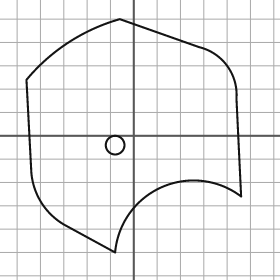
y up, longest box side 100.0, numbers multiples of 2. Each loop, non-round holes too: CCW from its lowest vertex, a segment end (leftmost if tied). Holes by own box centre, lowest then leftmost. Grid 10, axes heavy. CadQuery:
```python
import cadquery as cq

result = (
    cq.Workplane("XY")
    .moveTo(-8.0, -50.0)
    .threePointArc((12.0, -22.0), (46.0, -26.0))
    .lineTo(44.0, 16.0)
    .threePointArc((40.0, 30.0), (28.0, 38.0))
    .lineTo(-6.0, 50.0)
    .threePointArc((-28.0, 40.0), (-46.0, 24.0))
    .lineTo(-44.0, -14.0)
    .threePointArc((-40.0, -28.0), (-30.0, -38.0))
    .close()
    .moveTo(-8.0, -4.0)
    .circle(4.0)
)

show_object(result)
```